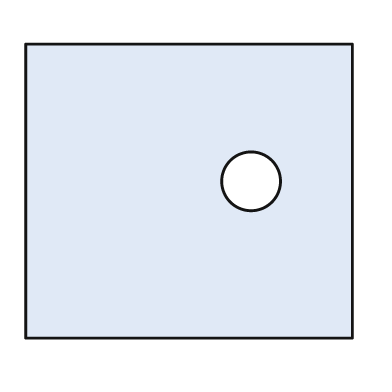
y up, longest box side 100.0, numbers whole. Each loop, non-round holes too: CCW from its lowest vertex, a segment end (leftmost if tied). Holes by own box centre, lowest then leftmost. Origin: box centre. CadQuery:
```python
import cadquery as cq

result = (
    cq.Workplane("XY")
    .moveTo(-50.0, -45.0)
    .lineTo(50.0, -45.0)
    .lineTo(50.0, 45.0)
    .lineTo(-50.0, 45.0)
    .close()
    .moveTo(19.0, 3.0)
    .circle(9.0)
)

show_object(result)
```